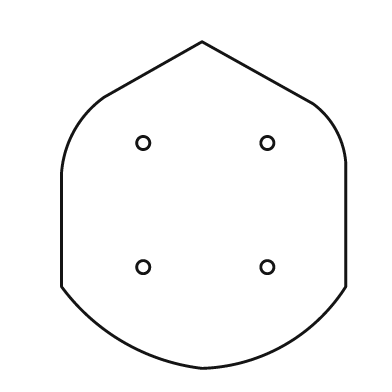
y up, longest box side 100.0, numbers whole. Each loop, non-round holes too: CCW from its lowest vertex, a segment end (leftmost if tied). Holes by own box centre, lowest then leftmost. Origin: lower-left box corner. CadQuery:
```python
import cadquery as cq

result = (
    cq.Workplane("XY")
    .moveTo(43.0, 0.0)
    .threePointArc((68.0, 7.0), (87.0, 25.0))
    .lineTo(87.0, 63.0)
    .threePointArc((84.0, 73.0), (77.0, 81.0))
    .lineTo(43.0, 100.0)
    .lineTo(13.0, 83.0)
    .threePointArc((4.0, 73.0), (0.0, 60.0))
    .lineTo(0.0, 25.0)
    .threePointArc((19.0, 8.0), (43.0, 0.0))
    .close()
    .moveTo(25.0, 31.0)
    .circle(2.0)
    .moveTo(63.0, 31.0)
    .circle(2.0)
    .moveTo(25.0, 69.0)
    .circle(2.0)
    .moveTo(63.0, 69.0)
    .circle(2.0)
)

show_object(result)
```